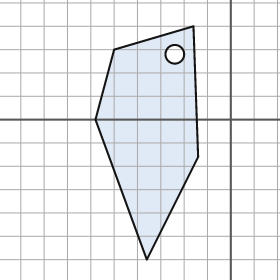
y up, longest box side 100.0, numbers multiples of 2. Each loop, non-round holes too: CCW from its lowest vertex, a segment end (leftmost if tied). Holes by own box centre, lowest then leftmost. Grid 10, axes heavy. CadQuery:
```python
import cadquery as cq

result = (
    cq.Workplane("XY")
    .moveTo(-36.0, -60.0)
    .lineTo(-14.0, -16.0)
    .lineTo(-16.0, 40.0)
    .lineTo(-50.0, 30.0)
    .lineTo(-58.0, 0.0)
    .close()
    .moveTo(-24.0, 28.0)
    .circle(4.0)
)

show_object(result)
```